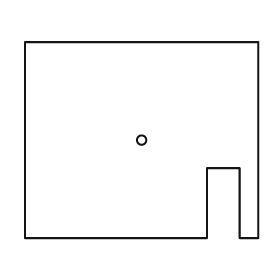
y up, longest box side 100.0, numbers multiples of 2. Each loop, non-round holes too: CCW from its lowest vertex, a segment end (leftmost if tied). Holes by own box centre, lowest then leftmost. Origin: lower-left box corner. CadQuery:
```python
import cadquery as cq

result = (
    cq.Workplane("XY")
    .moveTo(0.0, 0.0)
    .lineTo(78.0, 0.0)
    .lineTo(78.0, 30.0)
    .lineTo(92.0, 30.0)
    .lineTo(92.0, 0.0)
    .lineTo(100.0, 0.0)
    .lineTo(100.0, 84.0)
    .lineTo(0.0, 84.0)
    .close()
    .moveTo(50.0, 42.0)
    .circle(2.0)
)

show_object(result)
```